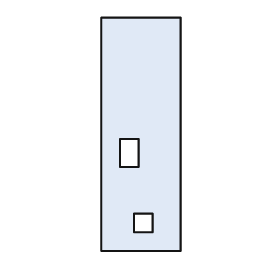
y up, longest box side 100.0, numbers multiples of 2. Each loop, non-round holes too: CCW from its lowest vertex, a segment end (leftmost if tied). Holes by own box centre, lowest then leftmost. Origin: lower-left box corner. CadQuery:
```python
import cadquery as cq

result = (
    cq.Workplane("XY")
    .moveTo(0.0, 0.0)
    .lineTo(34.0, 0.0)
    .lineTo(34.0, 100.0)
    .lineTo(0.0, 100.0)
    .close()
    .moveTo(14.0, 8.0)
    .lineTo(22.0, 8.0)
    .lineTo(22.0, 16.0)
    .lineTo(14.0, 16.0)
    .close()
    .moveTo(8.0, 36.0)
    .lineTo(16.0, 36.0)
    .lineTo(16.0, 48.0)
    .lineTo(8.0, 48.0)
    .close()
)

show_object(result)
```